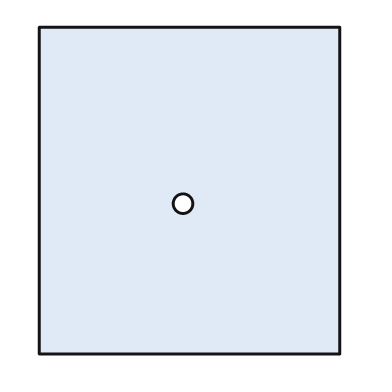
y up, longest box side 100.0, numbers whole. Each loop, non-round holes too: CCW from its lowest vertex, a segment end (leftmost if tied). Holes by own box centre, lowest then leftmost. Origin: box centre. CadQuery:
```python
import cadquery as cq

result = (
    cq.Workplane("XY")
    .moveTo(-46.0, -50.0)
    .lineTo(46.0, -50.0)
    .lineTo(46.0, 50.0)
    .lineTo(-46.0, 50.0)
    .close()
    .moveTo(-2.0, -4.0)
    .circle(3.0)
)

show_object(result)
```